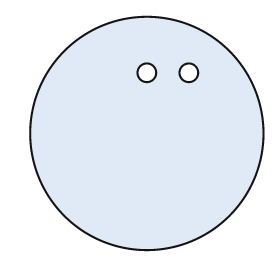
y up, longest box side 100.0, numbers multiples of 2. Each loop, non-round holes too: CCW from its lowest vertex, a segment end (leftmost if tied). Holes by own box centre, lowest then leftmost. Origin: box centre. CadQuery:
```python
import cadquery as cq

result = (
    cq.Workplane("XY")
    .moveTo(0.0, 0.0)
    .circle(50.0)
    .moveTo(0.0, 26.0)
    .circle(4.0)
    .moveTo(18.0, 26.0)
    .circle(4.0)
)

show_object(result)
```